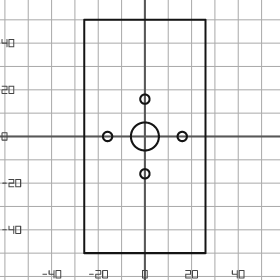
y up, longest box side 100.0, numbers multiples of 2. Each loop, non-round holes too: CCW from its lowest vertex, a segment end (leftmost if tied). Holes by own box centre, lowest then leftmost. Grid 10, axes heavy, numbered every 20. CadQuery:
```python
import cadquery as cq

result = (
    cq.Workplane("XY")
    .moveTo(-26.0, -50.0)
    .lineTo(26.0, -50.0)
    .lineTo(26.0, 50.0)
    .lineTo(-26.0, 50.0)
    .close()
    .moveTo(0.0, -16.0)
    .circle(2.0)
    .moveTo(-16.0, 0.0)
    .circle(2.0)
    .moveTo(0.0, 0.0)
    .circle(6.0)
    .moveTo(16.0, 0.0)
    .circle(2.0)
    .moveTo(0.0, 16.0)
    .circle(2.0)
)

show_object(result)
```